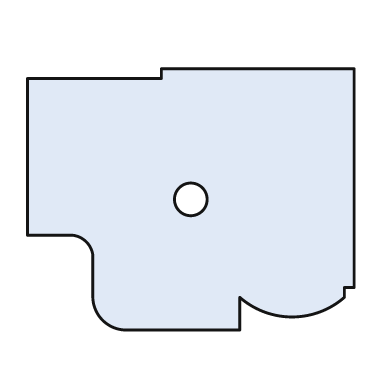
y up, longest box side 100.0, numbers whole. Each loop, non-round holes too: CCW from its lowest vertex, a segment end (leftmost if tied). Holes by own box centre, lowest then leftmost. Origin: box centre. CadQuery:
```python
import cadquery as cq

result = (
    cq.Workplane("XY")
    .moveTo(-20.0, -40.0)
    .lineTo(15.0, -40.0)
    .lineTo(15.0, -30.0)
    .threePointArc((31.0, -36.0), (47.0, -30.0))
    .lineTo(47.0, -27.0)
    .lineTo(50.0, -27.0)
    .lineTo(50.0, 40.0)
    .lineTo(-9.0, 40.0)
    .lineTo(-9.0, 37.0)
    .lineTo(-50.0, 37.0)
    .lineTo(-50.0, -11.0)
    .lineTo(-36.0, -11.0)
    .threePointArc((-32.0, -13.0), (-30.0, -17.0))
    .lineTo(-30.0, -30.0)
    .threePointArc((-27.0, -37.0), (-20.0, -40.0))
    .close()
    .moveTo(0.0, 0.0)
    .circle(5.0)
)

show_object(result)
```